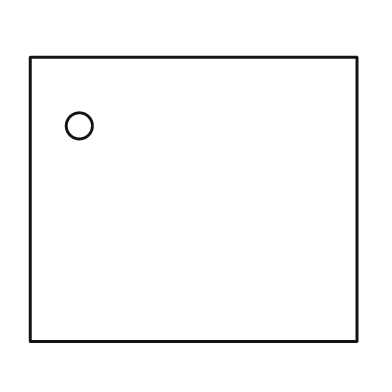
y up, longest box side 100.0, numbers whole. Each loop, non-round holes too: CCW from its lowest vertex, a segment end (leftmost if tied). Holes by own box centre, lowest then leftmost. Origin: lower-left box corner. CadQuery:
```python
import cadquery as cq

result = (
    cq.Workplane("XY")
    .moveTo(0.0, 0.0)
    .lineTo(100.0, 0.0)
    .lineTo(100.0, 87.0)
    .lineTo(0.0, 87.0)
    .close()
    .moveTo(15.0, 66.0)
    .circle(4.0)
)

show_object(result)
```